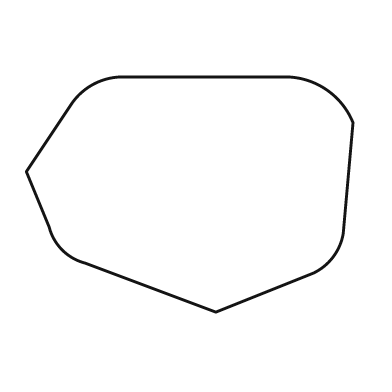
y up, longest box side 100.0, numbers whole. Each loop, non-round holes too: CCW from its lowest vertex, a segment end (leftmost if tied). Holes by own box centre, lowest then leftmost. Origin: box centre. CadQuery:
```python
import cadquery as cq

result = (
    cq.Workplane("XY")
    .moveTo(8.0, -36.0)
    .lineTo(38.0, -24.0)
    .threePointArc((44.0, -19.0), (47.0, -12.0))
    .lineTo(50.0, 22.0)
    .threePointArc((42.0, 32.0), (30.0, 36.0))
    .lineTo(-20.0, 36.0)
    .threePointArc((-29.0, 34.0), (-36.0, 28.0))
    .lineTo(-50.0, 7.0)
    .lineTo(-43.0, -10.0)
    .threePointArc((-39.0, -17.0), (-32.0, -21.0))
    .close()
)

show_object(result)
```